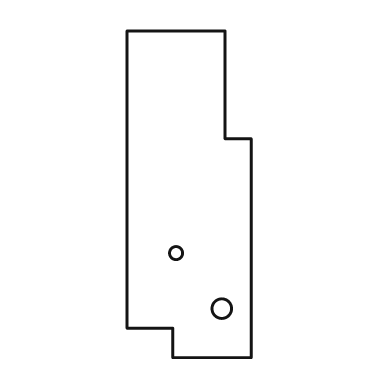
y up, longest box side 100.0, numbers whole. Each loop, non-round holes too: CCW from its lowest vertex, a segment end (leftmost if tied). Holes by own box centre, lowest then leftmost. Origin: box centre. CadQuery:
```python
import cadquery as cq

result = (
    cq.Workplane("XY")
    .moveTo(-5.0, -50.0)
    .lineTo(19.0, -50.0)
    .lineTo(19.0, 17.0)
    .lineTo(11.0, 17.0)
    .lineTo(11.0, 50.0)
    .lineTo(-19.0, 50.0)
    .lineTo(-19.0, -41.0)
    .lineTo(-5.0, -41.0)
    .close()
    .moveTo(10.0, -35.0)
    .circle(3.0)
    .moveTo(-4.0, -18.0)
    .circle(2.0)
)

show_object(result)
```